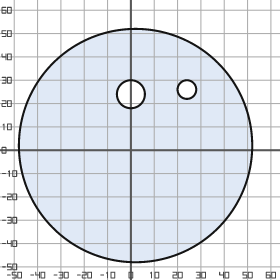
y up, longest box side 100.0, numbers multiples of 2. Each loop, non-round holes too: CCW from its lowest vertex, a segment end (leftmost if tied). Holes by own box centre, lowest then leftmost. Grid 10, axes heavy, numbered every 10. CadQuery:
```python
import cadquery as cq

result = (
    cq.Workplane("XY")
    .moveTo(2.0, 2.0)
    .circle(50.0)
    .moveTo(0.0, 24.0)
    .circle(6.0)
    .moveTo(24.0, 26.0)
    .circle(4.0)
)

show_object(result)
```